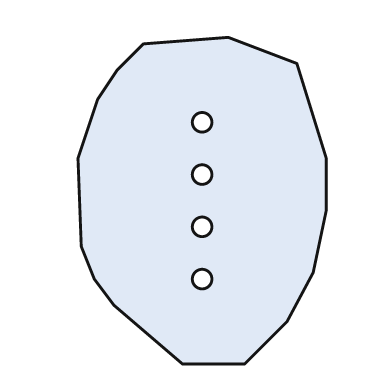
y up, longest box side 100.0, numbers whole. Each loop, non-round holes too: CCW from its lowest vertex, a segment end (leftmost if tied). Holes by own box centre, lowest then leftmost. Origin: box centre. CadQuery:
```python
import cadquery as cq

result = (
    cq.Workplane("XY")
    .moveTo(-6.0, -50.0)
    .lineTo(13.0, -50.0)
    .lineTo(26.0, -37.0)
    .lineTo(34.0, -22.0)
    .lineTo(38.0, -3.0)
    .lineTo(38.0, 13.0)
    .lineTo(29.0, 42.0)
    .lineTo(8.0, 50.0)
    .lineTo(-18.0, 48.0)
    .lineTo(-26.0, 40.0)
    .lineTo(-32.0, 31.0)
    .lineTo(-38.0, 13.0)
    .lineTo(-37.0, -14.0)
    .lineTo(-33.0, -24.0)
    .lineTo(-27.0, -32.0)
    .close()
    .moveTo(0.0, -24.0)
    .circle(3.0)
    .moveTo(0.0, -8.0)
    .circle(3.0)
    .moveTo(0.0, 8.0)
    .circle(3.0)
    .moveTo(0.0, 24.0)
    .circle(3.0)
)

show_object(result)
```